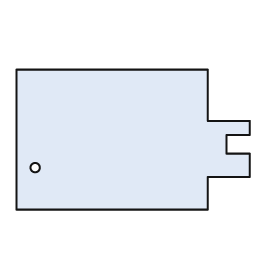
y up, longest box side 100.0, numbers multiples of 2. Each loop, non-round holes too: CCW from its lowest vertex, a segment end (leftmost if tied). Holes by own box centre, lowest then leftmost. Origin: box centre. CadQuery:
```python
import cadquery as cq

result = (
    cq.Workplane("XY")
    .moveTo(-50.0, -30.0)
    .lineTo(32.0, -30.0)
    .lineTo(32.0, -16.0)
    .lineTo(50.0, -16.0)
    .lineTo(50.0, -6.0)
    .lineTo(40.0, -6.0)
    .lineTo(40.0, 2.0)
    .lineTo(50.0, 2.0)
    .lineTo(50.0, 8.0)
    .lineTo(32.0, 8.0)
    .lineTo(32.0, 30.0)
    .lineTo(-50.0, 30.0)
    .close()
    .moveTo(-42.0, -12.0)
    .circle(2.0)
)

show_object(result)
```